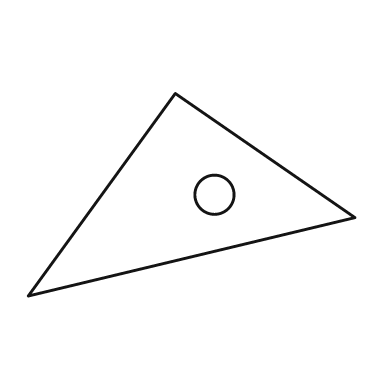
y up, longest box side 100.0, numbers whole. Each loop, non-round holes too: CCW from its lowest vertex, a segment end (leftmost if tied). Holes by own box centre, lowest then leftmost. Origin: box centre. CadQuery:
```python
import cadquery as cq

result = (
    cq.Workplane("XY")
    .moveTo(-50.0, -31.0)
    .lineTo(50.0, -7.0)
    .lineTo(-5.0, 31.0)
    .close()
    .moveTo(7.0, 0.0)
    .circle(6.0)
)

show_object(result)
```